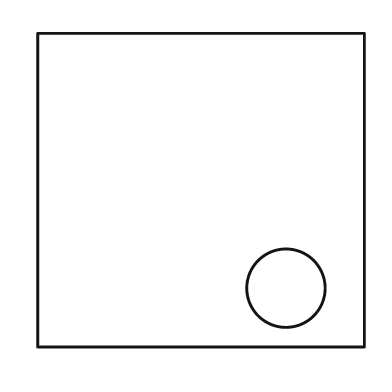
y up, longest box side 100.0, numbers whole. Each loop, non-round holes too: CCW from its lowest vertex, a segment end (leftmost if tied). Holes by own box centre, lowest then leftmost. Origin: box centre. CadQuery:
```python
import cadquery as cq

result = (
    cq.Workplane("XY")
    .moveTo(-50.0, -48.0)
    .lineTo(50.0, -48.0)
    .lineTo(50.0, 48.0)
    .lineTo(-50.0, 48.0)
    .close()
    .moveTo(26.0, -30.0)
    .circle(12.0)
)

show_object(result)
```